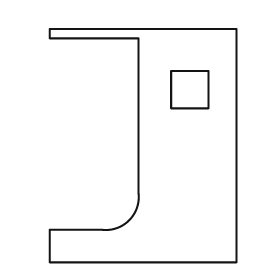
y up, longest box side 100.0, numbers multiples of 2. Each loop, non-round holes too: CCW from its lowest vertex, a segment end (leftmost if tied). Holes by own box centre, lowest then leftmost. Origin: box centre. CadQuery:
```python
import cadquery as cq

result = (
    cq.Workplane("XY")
    .moveTo(-40.0, -50.0)
    .lineTo(40.0, -50.0)
    .lineTo(40.0, 50.0)
    .lineTo(-40.0, 50.0)
    .lineTo(-40.0, 46.0)
    .lineTo(-2.0, 46.0)
    .lineTo(-2.0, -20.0)
    .threePointArc((-6.0, -32.0), (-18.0, -36.0))
    .lineTo(-40.0, -36.0)
    .close()
    .moveTo(12.0, 16.0)
    .lineTo(28.0, 16.0)
    .lineTo(28.0, 32.0)
    .lineTo(12.0, 32.0)
    .close()
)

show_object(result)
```